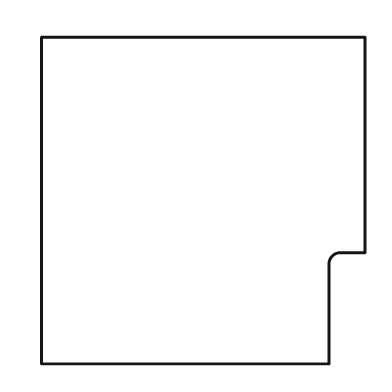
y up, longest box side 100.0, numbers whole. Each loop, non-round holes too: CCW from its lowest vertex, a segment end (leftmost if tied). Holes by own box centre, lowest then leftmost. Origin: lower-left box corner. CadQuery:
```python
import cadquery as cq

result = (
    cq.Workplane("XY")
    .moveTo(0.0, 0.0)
    .lineTo(88.0, 0.0)
    .lineTo(88.0, 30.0)
    .threePointArc((89.0, 33.0), (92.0, 34.0))
    .lineTo(99.0, 34.0)
    .lineTo(99.0, 100.0)
    .lineTo(0.0, 100.0)
    .close()
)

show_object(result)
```